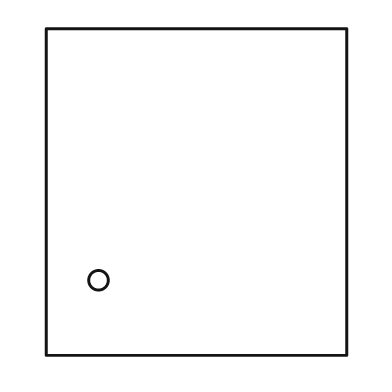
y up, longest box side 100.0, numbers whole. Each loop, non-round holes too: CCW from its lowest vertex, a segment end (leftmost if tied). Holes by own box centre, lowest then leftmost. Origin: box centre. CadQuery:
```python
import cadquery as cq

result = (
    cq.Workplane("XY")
    .moveTo(-46.0, -50.0)
    .lineTo(46.0, -50.0)
    .lineTo(46.0, 50.0)
    .lineTo(-46.0, 50.0)
    .close()
    .moveTo(-30.0, -27.0)
    .circle(3.0)
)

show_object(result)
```